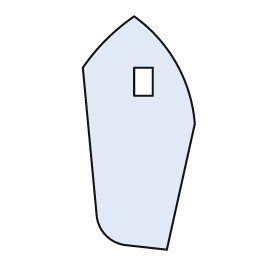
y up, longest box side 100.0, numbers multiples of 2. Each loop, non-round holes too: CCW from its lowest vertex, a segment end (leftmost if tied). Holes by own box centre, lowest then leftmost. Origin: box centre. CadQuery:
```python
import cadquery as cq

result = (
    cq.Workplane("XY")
    .moveTo(12.0, -50.0)
    .lineTo(24.0, 4.0)
    .threePointArc((16.0, 30.0), (-2.0, 50.0))
    .threePointArc((-14.0, 40.0), (-24.0, 28.0))
    .lineTo(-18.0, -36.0)
    .threePointArc((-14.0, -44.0), (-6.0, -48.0))
    .close()
    .moveTo(-2.0, 16.0)
    .lineTo(6.0, 16.0)
    .lineTo(6.0, 28.0)
    .lineTo(-2.0, 28.0)
    .close()
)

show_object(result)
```